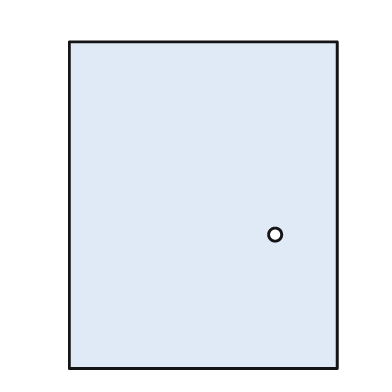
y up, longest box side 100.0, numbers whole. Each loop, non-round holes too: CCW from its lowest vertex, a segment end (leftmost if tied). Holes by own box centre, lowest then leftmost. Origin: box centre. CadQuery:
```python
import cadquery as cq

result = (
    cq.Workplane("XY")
    .moveTo(-41.0, -50.0)
    .lineTo(41.0, -50.0)
    .lineTo(41.0, 50.0)
    .lineTo(-41.0, 50.0)
    .close()
    .moveTo(22.0, -9.0)
    .circle(2.0)
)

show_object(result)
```